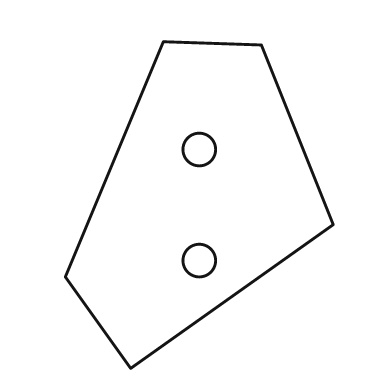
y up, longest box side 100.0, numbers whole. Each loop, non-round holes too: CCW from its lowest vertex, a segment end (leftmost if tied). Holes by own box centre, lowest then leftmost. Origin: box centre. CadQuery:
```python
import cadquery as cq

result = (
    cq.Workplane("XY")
    .moveTo(-21.0, -50.0)
    .lineTo(41.0, -6.0)
    .lineTo(19.0, 49.0)
    .lineTo(-11.0, 50.0)
    .lineTo(-41.0, -22.0)
    .close()
    .moveTo(0.0, -17.0)
    .circle(5.0)
    .moveTo(0.0, 17.0)
    .circle(5.0)
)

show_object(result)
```